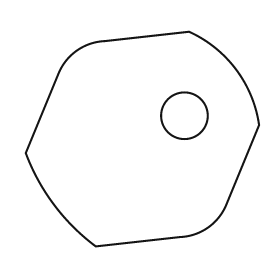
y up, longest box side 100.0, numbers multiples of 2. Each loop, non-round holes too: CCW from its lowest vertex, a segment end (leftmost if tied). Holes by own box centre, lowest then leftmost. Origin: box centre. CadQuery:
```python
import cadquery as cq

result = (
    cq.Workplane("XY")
    .moveTo(-20.0, -46.0)
    .lineTo(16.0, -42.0)
    .threePointArc((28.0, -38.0), (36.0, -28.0))
    .lineTo(50.0, 6.0)
    .threePointArc((40.0, 30.0), (20.0, 46.0))
    .lineTo(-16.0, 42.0)
    .threePointArc((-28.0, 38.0), (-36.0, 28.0))
    .lineTo(-50.0, -6.0)
    .threePointArc((-38.0, -28.0), (-20.0, -46.0))
    .close()
    .moveTo(18.0, 10.0)
    .circle(10.0)
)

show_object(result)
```